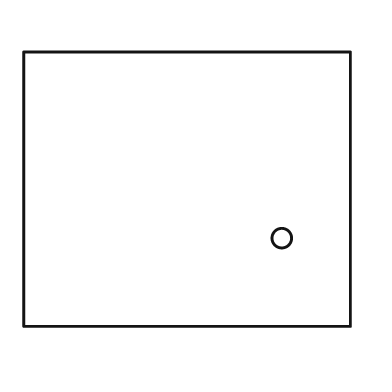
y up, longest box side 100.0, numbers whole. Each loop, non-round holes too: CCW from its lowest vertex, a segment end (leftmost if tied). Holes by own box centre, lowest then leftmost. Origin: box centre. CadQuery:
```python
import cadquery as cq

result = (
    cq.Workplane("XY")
    .moveTo(-50.0, -42.0)
    .lineTo(50.0, -42.0)
    .lineTo(50.0, 42.0)
    .lineTo(-50.0, 42.0)
    .close()
    .moveTo(29.0, -15.0)
    .circle(3.0)
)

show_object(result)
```